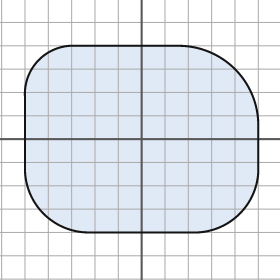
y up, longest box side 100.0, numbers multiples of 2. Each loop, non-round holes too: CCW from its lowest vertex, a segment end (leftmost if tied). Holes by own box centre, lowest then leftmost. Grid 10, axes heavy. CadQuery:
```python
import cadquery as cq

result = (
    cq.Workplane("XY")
    .moveTo(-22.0, -40.0)
    .lineTo(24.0, -40.0)
    .threePointArc((42.0, -32.0), (50.0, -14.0))
    .lineTo(50.0, 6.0)
    .threePointArc((40.0, 30.0), (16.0, 40.0))
    .lineTo(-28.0, 40.0)
    .threePointArc((-44.0, 34.0), (-50.0, 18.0))
    .lineTo(-50.0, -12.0)
    .threePointArc((-42.0, -32.0), (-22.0, -40.0))
    .close()
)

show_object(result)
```